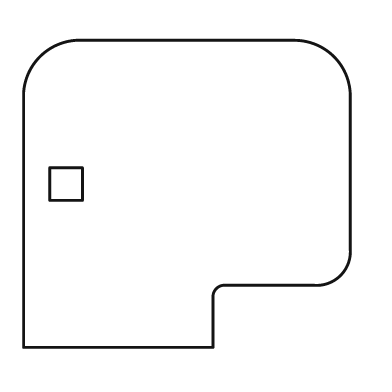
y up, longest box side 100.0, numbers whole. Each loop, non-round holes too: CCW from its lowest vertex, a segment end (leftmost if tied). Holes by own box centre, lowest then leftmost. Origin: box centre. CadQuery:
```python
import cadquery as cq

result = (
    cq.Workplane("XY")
    .moveTo(-50.0, -47.0)
    .lineTo(8.0, -47.0)
    .lineTo(8.0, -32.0)
    .threePointArc((9.0, -29.0), (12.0, -28.0))
    .lineTo(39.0, -28.0)
    .threePointArc((47.0, -25.0), (50.0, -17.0))
    .lineTo(50.0, 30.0)
    .threePointArc((45.0, 42.0), (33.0, 47.0))
    .lineTo(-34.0, 47.0)
    .threePointArc((-45.0, 42.0), (-50.0, 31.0))
    .close()
    .moveTo(-42.0, -2.0)
    .lineTo(-32.0, -2.0)
    .lineTo(-32.0, 8.0)
    .lineTo(-42.0, 8.0)
    .close()
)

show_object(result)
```